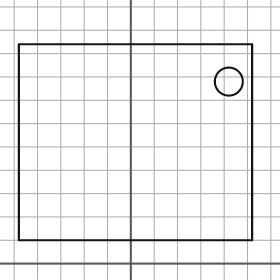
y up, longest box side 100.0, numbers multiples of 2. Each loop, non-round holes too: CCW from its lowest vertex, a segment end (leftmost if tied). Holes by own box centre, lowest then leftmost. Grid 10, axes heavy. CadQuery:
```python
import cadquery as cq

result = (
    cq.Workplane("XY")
    .moveTo(-48.0, 10.0)
    .lineTo(52.0, 10.0)
    .lineTo(52.0, 94.0)
    .lineTo(-48.0, 94.0)
    .close()
    .moveTo(42.0, 78.0)
    .circle(6.0)
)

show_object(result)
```